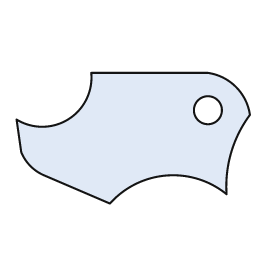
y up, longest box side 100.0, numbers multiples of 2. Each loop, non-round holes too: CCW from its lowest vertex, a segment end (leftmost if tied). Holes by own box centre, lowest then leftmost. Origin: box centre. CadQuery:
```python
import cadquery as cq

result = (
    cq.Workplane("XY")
    .moveTo(-10.0, -28.0)
    .threePointArc((14.0, -16.0), (40.0, -24.0))
    .threePointArc((42.0, -6.0), (50.0, 10.0))
    .threePointArc((44.0, 22.0), (32.0, 28.0))
    .lineTo(-18.0, 28.0)
    .threePointArc((-28.0, 8.0), (-50.0, 8.0))
    .lineTo(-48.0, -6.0)
    .threePointArc((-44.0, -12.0), (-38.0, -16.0))
    .close()
    .moveTo(32.0, 12.0)
    .circle(6.0)
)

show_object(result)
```